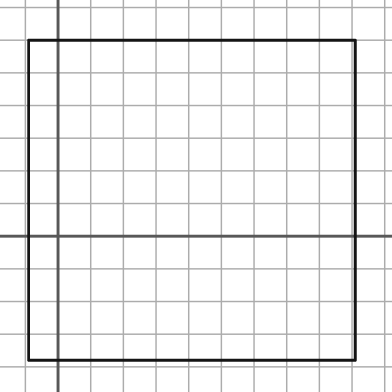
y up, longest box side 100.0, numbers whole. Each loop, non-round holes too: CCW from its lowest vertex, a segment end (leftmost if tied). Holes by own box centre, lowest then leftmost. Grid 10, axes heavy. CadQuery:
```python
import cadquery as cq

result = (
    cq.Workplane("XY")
    .moveTo(-9.0, -38.0)
    .lineTo(91.0, -38.0)
    .lineTo(91.0, 60.0)
    .lineTo(-9.0, 60.0)
    .close()
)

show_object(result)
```